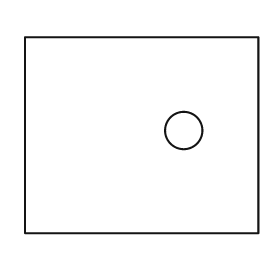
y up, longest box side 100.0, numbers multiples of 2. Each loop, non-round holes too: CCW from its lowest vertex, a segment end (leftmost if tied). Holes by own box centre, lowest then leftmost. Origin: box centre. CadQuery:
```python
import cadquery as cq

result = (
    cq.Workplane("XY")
    .moveTo(-50.0, -42.0)
    .lineTo(50.0, -42.0)
    .lineTo(50.0, 42.0)
    .lineTo(-50.0, 42.0)
    .close()
    .moveTo(18.0, 2.0)
    .circle(8.0)
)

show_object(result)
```